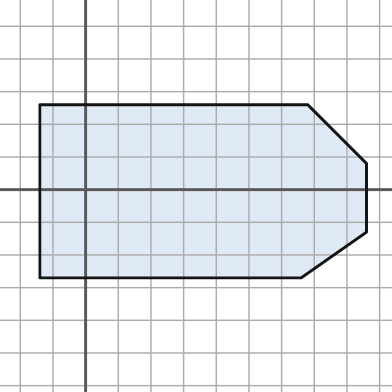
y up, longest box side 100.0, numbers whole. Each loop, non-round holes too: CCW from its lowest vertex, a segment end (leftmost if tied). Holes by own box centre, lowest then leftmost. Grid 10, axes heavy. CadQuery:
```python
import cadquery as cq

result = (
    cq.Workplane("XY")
    .moveTo(-14.0, -27.0)
    .lineTo(66.0, -27.0)
    .lineTo(86.0, -13.0)
    .lineTo(86.0, 8.0)
    .lineTo(68.0, 26.0)
    .lineTo(-14.0, 26.0)
    .close()
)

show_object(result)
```